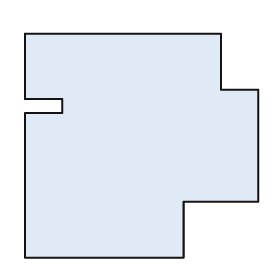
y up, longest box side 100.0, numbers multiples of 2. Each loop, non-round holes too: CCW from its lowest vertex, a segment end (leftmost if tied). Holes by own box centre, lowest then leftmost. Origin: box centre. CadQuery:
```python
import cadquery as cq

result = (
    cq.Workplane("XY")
    .moveTo(-50.0, -48.0)
    .lineTo(18.0, -48.0)
    .lineTo(18.0, -24.0)
    .lineTo(50.0, -24.0)
    .lineTo(50.0, 24.0)
    .lineTo(34.0, 24.0)
    .lineTo(34.0, 48.0)
    .lineTo(-50.0, 48.0)
    .lineTo(-50.0, 20.0)
    .lineTo(-34.0, 20.0)
    .lineTo(-34.0, 14.0)
    .lineTo(-50.0, 14.0)
    .close()
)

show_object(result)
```